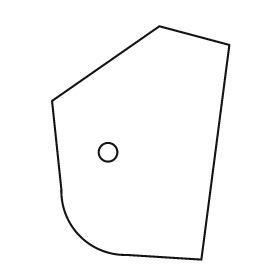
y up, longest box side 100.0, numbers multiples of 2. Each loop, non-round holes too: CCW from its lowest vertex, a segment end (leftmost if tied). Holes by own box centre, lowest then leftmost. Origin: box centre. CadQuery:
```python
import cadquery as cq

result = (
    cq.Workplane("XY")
    .moveTo(26.0, -50.0)
    .lineTo(38.0, 42.0)
    .lineTo(8.0, 50.0)
    .lineTo(-38.0, 18.0)
    .lineTo(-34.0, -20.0)
    .threePointArc((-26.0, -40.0), (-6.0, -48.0))
    .close()
    .moveTo(-14.0, -4.0)
    .circle(4.0)
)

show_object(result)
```